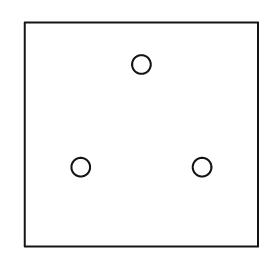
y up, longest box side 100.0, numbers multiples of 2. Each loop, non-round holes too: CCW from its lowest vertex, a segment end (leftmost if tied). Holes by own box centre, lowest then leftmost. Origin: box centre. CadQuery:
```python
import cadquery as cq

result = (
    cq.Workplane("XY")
    .moveTo(-50.0, -48.0)
    .lineTo(50.0, -48.0)
    .lineTo(50.0, 48.0)
    .lineTo(-50.0, 48.0)
    .close()
    .moveTo(-26.0, -14.0)
    .circle(4.0)
    .moveTo(26.0, -14.0)
    .circle(4.0)
    .moveTo(0.0, 30.0)
    .circle(4.0)
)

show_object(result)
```